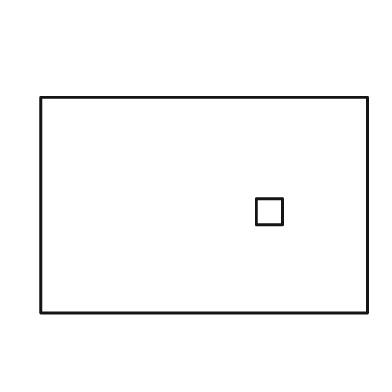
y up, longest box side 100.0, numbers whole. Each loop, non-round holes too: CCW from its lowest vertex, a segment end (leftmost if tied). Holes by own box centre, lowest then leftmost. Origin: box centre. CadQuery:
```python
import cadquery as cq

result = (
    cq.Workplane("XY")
    .moveTo(-50.0, -33.0)
    .lineTo(50.0, -33.0)
    .lineTo(50.0, 33.0)
    .lineTo(-50.0, 33.0)
    .close()
    .moveTo(16.0, -6.0)
    .lineTo(24.0, -6.0)
    .lineTo(24.0, 2.0)
    .lineTo(16.0, 2.0)
    .close()
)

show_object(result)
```